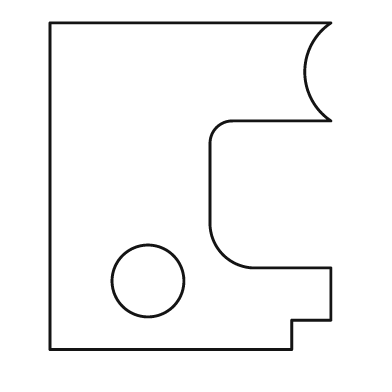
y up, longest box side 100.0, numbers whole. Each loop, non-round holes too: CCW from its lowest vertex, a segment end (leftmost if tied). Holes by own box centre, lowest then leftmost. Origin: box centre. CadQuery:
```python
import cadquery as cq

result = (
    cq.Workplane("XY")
    .moveTo(-43.0, -50.0)
    .lineTo(31.0, -50.0)
    .lineTo(31.0, -41.0)
    .lineTo(43.0, -41.0)
    .lineTo(43.0, -25.0)
    .lineTo(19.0, -25.0)
    .threePointArc((10.0, -21.0), (6.0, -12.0))
    .lineTo(6.0, 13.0)
    .threePointArc((8.0, 18.0), (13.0, 20.0))
    .lineTo(43.0, 20.0)
    .threePointArc((35.0, 35.0), (43.0, 50.0))
    .lineTo(-43.0, 50.0)
    .close()
    .moveTo(-13.0, -29.0)
    .circle(11.0)
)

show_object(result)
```